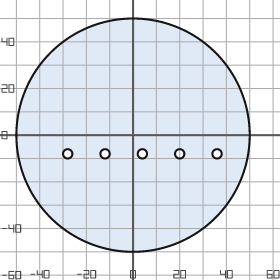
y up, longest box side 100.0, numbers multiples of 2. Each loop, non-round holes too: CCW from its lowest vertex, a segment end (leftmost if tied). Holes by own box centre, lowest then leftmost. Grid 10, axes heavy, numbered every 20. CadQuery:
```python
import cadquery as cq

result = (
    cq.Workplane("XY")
    .moveTo(0.0, 0.0)
    .circle(50.0)
    .moveTo(-28.0, -8.0)
    .circle(2.0)
    .moveTo(-12.0, -8.0)
    .circle(2.0)
    .moveTo(4.0, -8.0)
    .circle(2.0)
    .moveTo(20.0, -8.0)
    .circle(2.0)
    .moveTo(36.0, -8.0)
    .circle(2.0)
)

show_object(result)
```